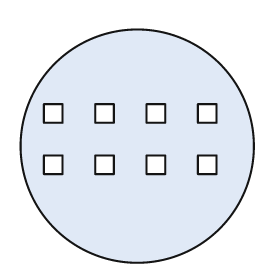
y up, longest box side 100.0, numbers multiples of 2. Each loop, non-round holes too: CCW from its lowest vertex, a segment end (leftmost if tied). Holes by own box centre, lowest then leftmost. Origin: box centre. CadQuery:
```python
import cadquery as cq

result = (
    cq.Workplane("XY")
    .moveTo(0.0, 0.0)
    .circle(50.0)
    .moveTo(-40.0, -12.0)
    .lineTo(-32.0, -12.0)
    .lineTo(-32.0, -4.0)
    .lineTo(-40.0, -4.0)
    .close()
    .moveTo(-18.0, -12.0)
    .lineTo(-10.0, -12.0)
    .lineTo(-10.0, -4.0)
    .lineTo(-18.0, -4.0)
    .close()
    .moveTo(4.0, -12.0)
    .lineTo(12.0, -12.0)
    .lineTo(12.0, -4.0)
    .lineTo(4.0, -4.0)
    .close()
    .moveTo(26.0, -12.0)
    .lineTo(34.0, -12.0)
    .lineTo(34.0, -4.0)
    .lineTo(26.0, -4.0)
    .close()
    .moveTo(-40.0, 10.0)
    .lineTo(-32.0, 10.0)
    .lineTo(-32.0, 18.0)
    .lineTo(-40.0, 18.0)
    .close()
    .moveTo(-18.0, 10.0)
    .lineTo(-10.0, 10.0)
    .lineTo(-10.0, 18.0)
    .lineTo(-18.0, 18.0)
    .close()
    .moveTo(4.0, 10.0)
    .lineTo(12.0, 10.0)
    .lineTo(12.0, 18.0)
    .lineTo(4.0, 18.0)
    .close()
    .moveTo(26.0, 10.0)
    .lineTo(34.0, 10.0)
    .lineTo(34.0, 18.0)
    .lineTo(26.0, 18.0)
    .close()
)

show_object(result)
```